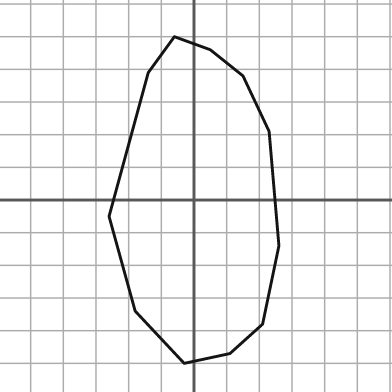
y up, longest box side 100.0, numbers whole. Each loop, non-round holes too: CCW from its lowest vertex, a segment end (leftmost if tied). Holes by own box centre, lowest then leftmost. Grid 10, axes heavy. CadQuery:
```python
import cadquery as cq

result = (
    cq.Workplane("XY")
    .moveTo(-3.0, -50.0)
    .lineTo(11.0, -47.0)
    .lineTo(21.0, -38.0)
    .lineTo(26.0, -14.0)
    .lineTo(23.0, 21.0)
    .lineTo(15.0, 38.0)
    .lineTo(5.0, 46.0)
    .lineTo(-6.0, 50.0)
    .lineTo(-14.0, 39.0)
    .lineTo(-26.0, -5.0)
    .lineTo(-18.0, -34.0)
    .close()
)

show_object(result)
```